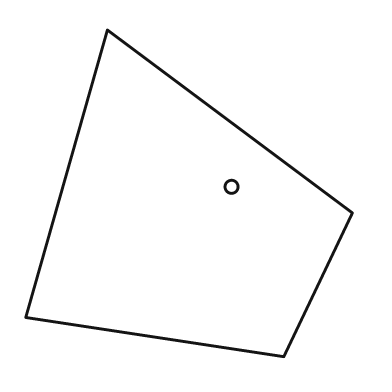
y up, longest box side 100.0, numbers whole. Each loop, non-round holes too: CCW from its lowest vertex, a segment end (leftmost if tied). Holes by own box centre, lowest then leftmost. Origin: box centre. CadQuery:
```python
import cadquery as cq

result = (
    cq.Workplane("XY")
    .moveTo(29.0, -50.0)
    .lineTo(50.0, -6.0)
    .lineTo(-25.0, 50.0)
    .lineTo(-50.0, -38.0)
    .close()
    .moveTo(13.0, 2.0)
    .circle(2.0)
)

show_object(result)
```